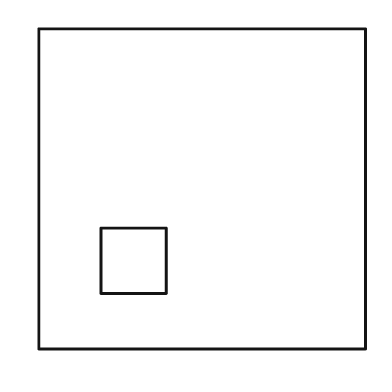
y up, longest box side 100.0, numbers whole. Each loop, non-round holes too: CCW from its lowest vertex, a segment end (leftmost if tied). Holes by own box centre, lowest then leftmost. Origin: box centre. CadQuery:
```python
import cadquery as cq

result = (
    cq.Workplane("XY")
    .moveTo(-50.0, -49.0)
    .lineTo(50.0, -49.0)
    .lineTo(50.0, 49.0)
    .lineTo(-50.0, 49.0)
    .close()
    .moveTo(-31.0, -32.0)
    .lineTo(-11.0, -32.0)
    .lineTo(-11.0, -12.0)
    .lineTo(-31.0, -12.0)
    .close()
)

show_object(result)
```